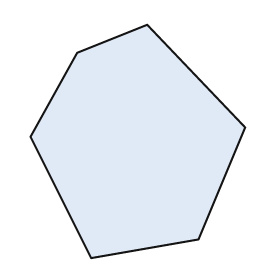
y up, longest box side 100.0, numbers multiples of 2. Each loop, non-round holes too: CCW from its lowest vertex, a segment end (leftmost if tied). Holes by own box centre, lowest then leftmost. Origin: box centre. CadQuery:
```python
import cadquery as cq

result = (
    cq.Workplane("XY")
    .moveTo(-20.0, -50.0)
    .lineTo(26.0, -42.0)
    .lineTo(46.0, 6.0)
    .lineTo(4.0, 50.0)
    .lineTo(-26.0, 38.0)
    .lineTo(-46.0, 2.0)
    .close()
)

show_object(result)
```